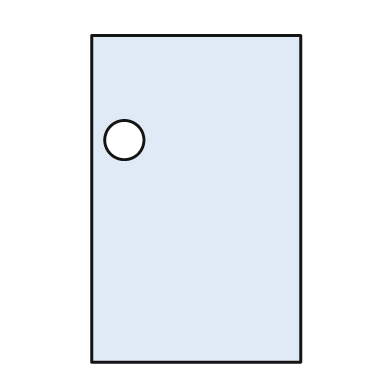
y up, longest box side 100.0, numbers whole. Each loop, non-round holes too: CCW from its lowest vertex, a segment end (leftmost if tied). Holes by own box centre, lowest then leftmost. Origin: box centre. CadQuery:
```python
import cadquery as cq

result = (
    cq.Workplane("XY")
    .moveTo(-32.0, -50.0)
    .lineTo(32.0, -50.0)
    .lineTo(32.0, 50.0)
    .lineTo(-32.0, 50.0)
    .close()
    .moveTo(-22.0, 18.0)
    .circle(6.0)
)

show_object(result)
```